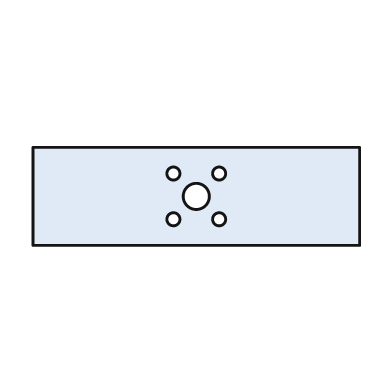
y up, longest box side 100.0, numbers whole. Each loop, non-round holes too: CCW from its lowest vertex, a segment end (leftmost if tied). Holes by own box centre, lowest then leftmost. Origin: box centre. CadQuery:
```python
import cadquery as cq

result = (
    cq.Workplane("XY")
    .moveTo(-50.0, -15.0)
    .lineTo(50.0, -15.0)
    .lineTo(50.0, 15.0)
    .lineTo(-50.0, 15.0)
    .close()
    .moveTo(-7.0, -7.0)
    .circle(2.0)
    .moveTo(7.0, -7.0)
    .circle(2.0)
    .moveTo(0.0, 0.0)
    .circle(4.0)
    .moveTo(-7.0, 7.0)
    .circle(2.0)
    .moveTo(7.0, 7.0)
    .circle(2.0)
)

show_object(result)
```